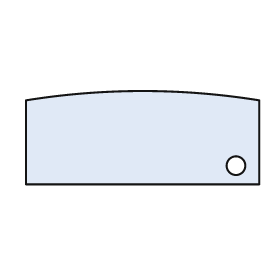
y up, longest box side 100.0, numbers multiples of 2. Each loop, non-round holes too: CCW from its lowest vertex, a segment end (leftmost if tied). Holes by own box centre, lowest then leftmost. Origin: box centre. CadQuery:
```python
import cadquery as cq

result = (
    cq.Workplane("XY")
    .moveTo(-50.0, -20.0)
    .lineTo(50.0, -20.0)
    .lineTo(50.0, 16.0)
    .threePointArc((0.0, 20.0), (-50.0, 16.0))
    .close()
    .moveTo(40.0, -12.0)
    .circle(4.0)
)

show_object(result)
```